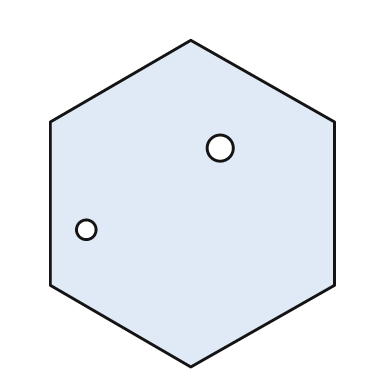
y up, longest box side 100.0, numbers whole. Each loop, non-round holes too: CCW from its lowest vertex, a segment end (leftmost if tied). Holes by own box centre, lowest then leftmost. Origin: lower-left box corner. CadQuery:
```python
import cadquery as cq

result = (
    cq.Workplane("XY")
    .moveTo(43.0, 0.0)
    .lineTo(87.0, 25.0)
    .lineTo(87.0, 75.0)
    .lineTo(43.0, 100.0)
    .lineTo(0.0, 75.0)
    .lineTo(0.0, 25.0)
    .close()
    .moveTo(11.0, 42.0)
    .circle(3.0)
    .moveTo(52.0, 67.0)
    .circle(4.0)
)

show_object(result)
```